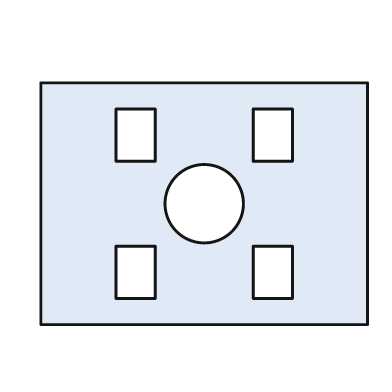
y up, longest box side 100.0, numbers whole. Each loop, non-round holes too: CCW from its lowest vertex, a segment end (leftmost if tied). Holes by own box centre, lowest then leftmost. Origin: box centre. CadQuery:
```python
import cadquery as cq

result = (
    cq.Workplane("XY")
    .moveTo(-50.0, -37.0)
    .lineTo(50.0, -37.0)
    .lineTo(50.0, 37.0)
    .lineTo(-50.0, 37.0)
    .close()
    .moveTo(-27.0, -29.0)
    .lineTo(-15.0, -29.0)
    .lineTo(-15.0, -13.0)
    .lineTo(-27.0, -13.0)
    .close()
    .moveTo(15.0, -29.0)
    .lineTo(27.0, -29.0)
    .lineTo(27.0, -13.0)
    .lineTo(15.0, -13.0)
    .close()
    .moveTo(0.0, 0.0)
    .circle(12.0)
    .moveTo(-27.0, 13.0)
    .lineTo(-15.0, 13.0)
    .lineTo(-15.0, 29.0)
    .lineTo(-27.0, 29.0)
    .close()
    .moveTo(15.0, 13.0)
    .lineTo(27.0, 13.0)
    .lineTo(27.0, 29.0)
    .lineTo(15.0, 29.0)
    .close()
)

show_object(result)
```